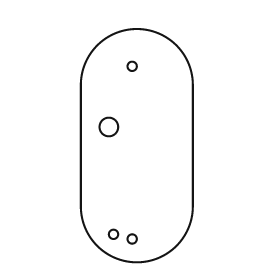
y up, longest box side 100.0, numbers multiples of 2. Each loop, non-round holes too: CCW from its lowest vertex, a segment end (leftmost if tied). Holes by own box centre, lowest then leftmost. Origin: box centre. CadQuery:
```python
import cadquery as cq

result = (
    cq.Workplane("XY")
    .moveTo(-24.0, -26.0)
    .threePointArc((0.0, -50.0), (24.0, -26.0))
    .lineTo(24.0, 26.0)
    .threePointArc((0.0, 50.0), (-24.0, 26.0))
    .close()
    .moveTo(-2.0, -40.0)
    .circle(2.0)
    .moveTo(-10.0, -38.0)
    .circle(2.0)
    .moveTo(-12.0, 8.0)
    .circle(4.0)
    .moveTo(-2.0, 34.0)
    .circle(2.0)
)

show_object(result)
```